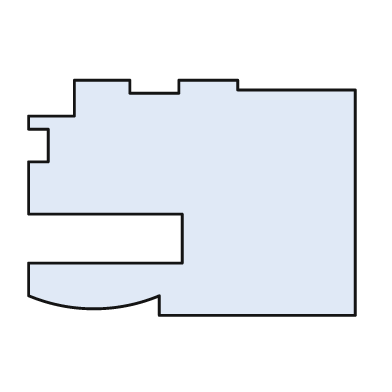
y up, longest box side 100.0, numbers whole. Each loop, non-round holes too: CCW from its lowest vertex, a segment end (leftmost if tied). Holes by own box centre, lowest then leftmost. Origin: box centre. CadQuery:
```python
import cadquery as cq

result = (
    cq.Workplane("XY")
    .moveTo(-10.0, -36.0)
    .lineTo(50.0, -36.0)
    .lineTo(50.0, 33.0)
    .lineTo(14.0, 33.0)
    .lineTo(14.0, 36.0)
    .lineTo(-4.0, 36.0)
    .lineTo(-4.0, 32.0)
    .lineTo(-19.0, 32.0)
    .lineTo(-19.0, 36.0)
    .lineTo(-36.0, 36.0)
    .lineTo(-36.0, 25.0)
    .lineTo(-50.0, 25.0)
    .lineTo(-50.0, 21.0)
    .lineTo(-44.0, 21.0)
    .lineTo(-44.0, 11.0)
    .lineTo(-50.0, 11.0)
    .lineTo(-50.0, -5.0)
    .lineTo(-3.0, -5.0)
    .lineTo(-3.0, -20.0)
    .lineTo(-50.0, -20.0)
    .lineTo(-50.0, -30.0)
    .threePointArc((-30.0, -34.0), (-10.0, -30.0))
    .close()
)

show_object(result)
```